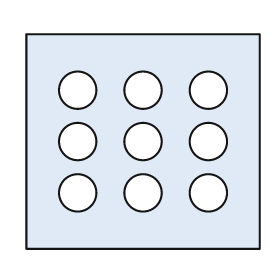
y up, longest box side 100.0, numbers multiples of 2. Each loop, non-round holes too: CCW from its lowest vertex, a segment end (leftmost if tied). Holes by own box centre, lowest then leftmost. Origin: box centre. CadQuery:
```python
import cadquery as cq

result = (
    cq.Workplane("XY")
    .moveTo(-50.0, -46.0)
    .lineTo(50.0, -46.0)
    .lineTo(50.0, 46.0)
    .lineTo(-50.0, 46.0)
    .close()
    .moveTo(-28.0, -22.0)
    .circle(8.0)
    .moveTo(0.0, -22.0)
    .circle(8.0)
    .moveTo(28.0, -22.0)
    .circle(8.0)
    .moveTo(-28.0, 0.0)
    .circle(8.0)
    .moveTo(0.0, 0.0)
    .circle(8.0)
    .moveTo(28.0, 0.0)
    .circle(8.0)
    .moveTo(-28.0, 22.0)
    .circle(8.0)
    .moveTo(0.0, 22.0)
    .circle(8.0)
    .moveTo(28.0, 22.0)
    .circle(8.0)
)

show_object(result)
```